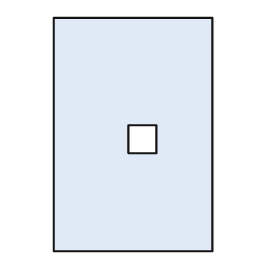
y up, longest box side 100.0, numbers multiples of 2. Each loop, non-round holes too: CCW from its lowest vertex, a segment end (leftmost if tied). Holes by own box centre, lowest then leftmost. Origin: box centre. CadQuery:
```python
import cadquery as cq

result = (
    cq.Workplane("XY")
    .moveTo(-34.0, -50.0)
    .lineTo(34.0, -50.0)
    .lineTo(34.0, 50.0)
    .lineTo(-34.0, 50.0)
    .close()
    .moveTo(-2.0, -8.0)
    .lineTo(10.0, -8.0)
    .lineTo(10.0, 4.0)
    .lineTo(-2.0, 4.0)
    .close()
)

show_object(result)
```